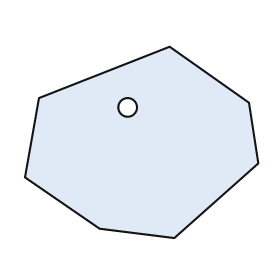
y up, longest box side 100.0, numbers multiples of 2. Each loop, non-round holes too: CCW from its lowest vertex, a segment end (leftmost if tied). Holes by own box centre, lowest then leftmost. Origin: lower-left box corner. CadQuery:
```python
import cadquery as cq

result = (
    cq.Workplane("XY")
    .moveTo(64.0, 0.0)
    .lineTo(100.0, 32.0)
    .lineTo(96.0, 58.0)
    .lineTo(62.0, 82.0)
    .lineTo(6.0, 60.0)
    .lineTo(0.0, 26.0)
    .lineTo(32.0, 4.0)
    .close()
    .moveTo(44.0, 56.0)
    .circle(4.0)
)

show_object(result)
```